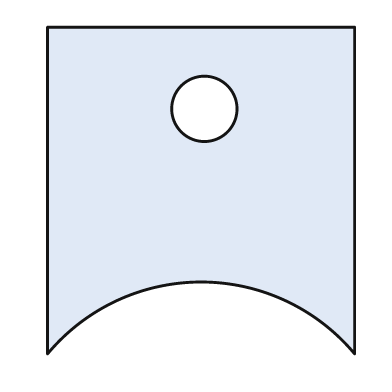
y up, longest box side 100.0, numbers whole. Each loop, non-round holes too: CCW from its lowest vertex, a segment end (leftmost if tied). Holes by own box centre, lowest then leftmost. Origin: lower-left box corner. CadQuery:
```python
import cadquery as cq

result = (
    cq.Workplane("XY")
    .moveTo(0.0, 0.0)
    .threePointArc((47.0, 22.0), (94.0, 0.0))
    .lineTo(94.0, 100.0)
    .lineTo(0.0, 100.0)
    .close()
    .moveTo(48.0, 75.0)
    .circle(10.0)
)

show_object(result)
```